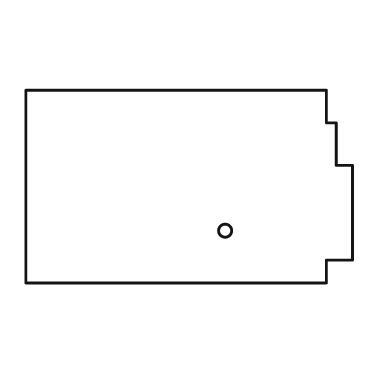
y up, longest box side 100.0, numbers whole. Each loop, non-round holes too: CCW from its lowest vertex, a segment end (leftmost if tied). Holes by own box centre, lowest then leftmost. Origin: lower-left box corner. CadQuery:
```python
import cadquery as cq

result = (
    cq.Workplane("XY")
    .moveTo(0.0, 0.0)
    .lineTo(92.0, 0.0)
    .lineTo(92.0, 7.0)
    .lineTo(100.0, 7.0)
    .lineTo(100.0, 36.0)
    .lineTo(95.0, 36.0)
    .lineTo(95.0, 49.0)
    .lineTo(92.0, 49.0)
    .lineTo(92.0, 59.0)
    .lineTo(0.0, 59.0)
    .close()
    .moveTo(61.0, 16.0)
    .circle(2.0)
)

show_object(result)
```